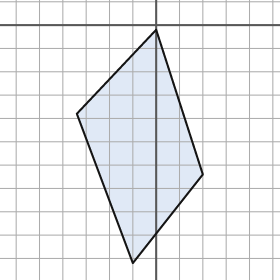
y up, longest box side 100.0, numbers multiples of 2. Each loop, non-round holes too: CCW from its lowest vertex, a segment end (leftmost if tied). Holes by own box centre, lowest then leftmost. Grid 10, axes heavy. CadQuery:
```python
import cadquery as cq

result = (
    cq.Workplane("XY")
    .moveTo(-10.0, -102.0)
    .lineTo(20.0, -64.0)
    .lineTo(0.0, -2.0)
    .lineTo(-34.0, -38.0)
    .close()
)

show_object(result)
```